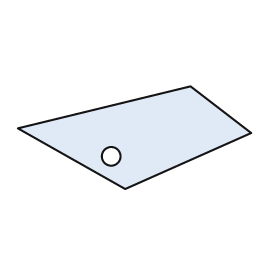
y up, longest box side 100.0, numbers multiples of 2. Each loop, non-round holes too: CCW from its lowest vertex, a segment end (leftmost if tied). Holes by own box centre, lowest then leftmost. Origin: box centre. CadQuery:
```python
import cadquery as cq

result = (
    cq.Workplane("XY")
    .moveTo(-4.0, -22.0)
    .lineTo(50.0, 2.0)
    .lineTo(24.0, 22.0)
    .lineTo(-50.0, 4.0)
    .close()
    .moveTo(-10.0, -8.0)
    .circle(4.0)
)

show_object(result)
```